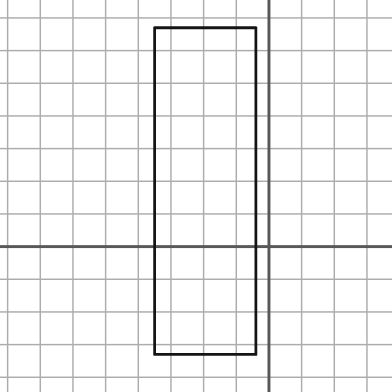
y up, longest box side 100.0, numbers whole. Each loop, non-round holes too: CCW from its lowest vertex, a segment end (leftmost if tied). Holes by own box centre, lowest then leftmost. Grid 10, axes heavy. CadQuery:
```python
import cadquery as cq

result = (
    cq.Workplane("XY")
    .moveTo(-35.0, -33.0)
    .lineTo(-4.0, -33.0)
    .lineTo(-4.0, 67.0)
    .lineTo(-35.0, 67.0)
    .close()
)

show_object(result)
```